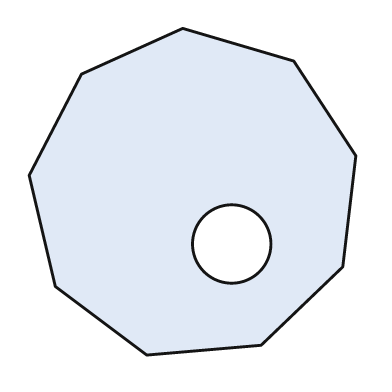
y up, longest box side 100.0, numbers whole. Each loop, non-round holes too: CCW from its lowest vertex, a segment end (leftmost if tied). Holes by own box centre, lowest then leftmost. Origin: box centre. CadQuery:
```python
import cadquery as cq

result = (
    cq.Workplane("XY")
    .moveTo(-14.0, -50.0)
    .lineTo(21.0, -47.0)
    .lineTo(46.0, -23.0)
    .lineTo(50.0, 11.0)
    .lineTo(31.0, 40.0)
    .lineTo(-3.0, 50.0)
    .lineTo(-34.0, 36.0)
    .lineTo(-50.0, 5.0)
    .lineTo(-42.0, -29.0)
    .close()
    .moveTo(12.0, -16.0)
    .circle(12.0)
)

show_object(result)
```